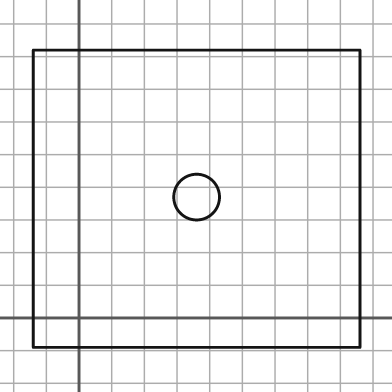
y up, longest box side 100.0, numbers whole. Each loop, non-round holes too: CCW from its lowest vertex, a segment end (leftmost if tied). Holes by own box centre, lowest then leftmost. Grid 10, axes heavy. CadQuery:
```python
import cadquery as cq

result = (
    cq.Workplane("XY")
    .moveTo(-14.0, -9.0)
    .lineTo(86.0, -9.0)
    .lineTo(86.0, 82.0)
    .lineTo(-14.0, 82.0)
    .close()
    .moveTo(36.0, 37.0)
    .circle(7.0)
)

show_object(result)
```